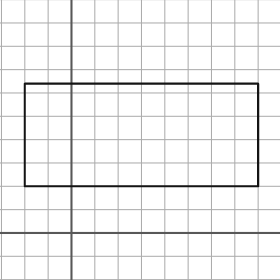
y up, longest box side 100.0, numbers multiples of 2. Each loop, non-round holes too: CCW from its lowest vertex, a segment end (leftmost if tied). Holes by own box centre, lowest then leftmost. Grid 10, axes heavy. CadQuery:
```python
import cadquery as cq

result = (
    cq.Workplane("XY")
    .moveTo(-20.0, 20.0)
    .lineTo(80.0, 20.0)
    .lineTo(80.0, 64.0)
    .lineTo(-20.0, 64.0)
    .close()
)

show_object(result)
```